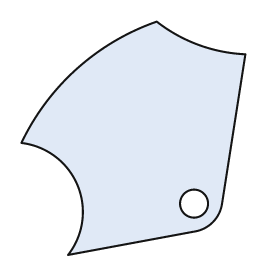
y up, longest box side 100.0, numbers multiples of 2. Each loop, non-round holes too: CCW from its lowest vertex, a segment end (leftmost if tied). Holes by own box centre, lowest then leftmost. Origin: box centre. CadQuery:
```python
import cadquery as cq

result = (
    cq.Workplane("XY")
    .moveTo(-28.0, -50.0)
    .lineTo(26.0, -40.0)
    .threePointArc((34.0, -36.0), (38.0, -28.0))
    .lineTo(48.0, 36.0)
    .threePointArc((28.0, 40.0), (10.0, 50.0))
    .threePointArc((-24.0, 30.0), (-48.0, -2.0))
    .threePointArc((-24.0, -20.0), (-28.0, -50.0))
    .close()
    .moveTo(26.0, -28.0)
    .circle(6.0)
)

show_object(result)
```